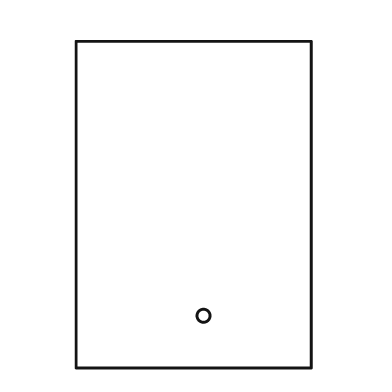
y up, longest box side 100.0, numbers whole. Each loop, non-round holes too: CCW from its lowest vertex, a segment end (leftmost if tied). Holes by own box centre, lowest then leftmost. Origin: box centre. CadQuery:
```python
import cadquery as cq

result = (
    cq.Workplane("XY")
    .moveTo(-36.0, -50.0)
    .lineTo(36.0, -50.0)
    .lineTo(36.0, 50.0)
    .lineTo(-36.0, 50.0)
    .close()
    .moveTo(3.0, -34.0)
    .circle(2.0)
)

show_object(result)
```